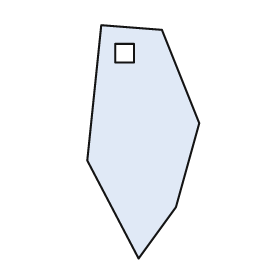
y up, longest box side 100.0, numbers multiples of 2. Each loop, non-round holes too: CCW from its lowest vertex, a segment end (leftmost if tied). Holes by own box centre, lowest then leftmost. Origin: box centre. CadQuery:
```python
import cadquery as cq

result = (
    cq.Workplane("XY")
    .moveTo(-2.0, -50.0)
    .lineTo(14.0, -28.0)
    .lineTo(24.0, 8.0)
    .lineTo(8.0, 48.0)
    .lineTo(-18.0, 50.0)
    .lineTo(-24.0, -8.0)
    .close()
    .moveTo(-12.0, 34.0)
    .lineTo(-4.0, 34.0)
    .lineTo(-4.0, 42.0)
    .lineTo(-12.0, 42.0)
    .close()
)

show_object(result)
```